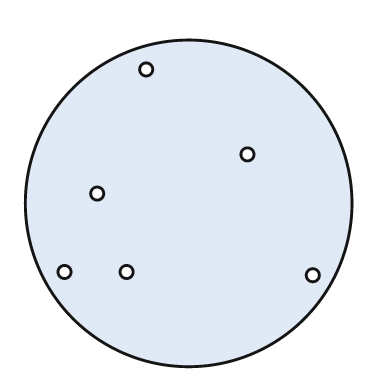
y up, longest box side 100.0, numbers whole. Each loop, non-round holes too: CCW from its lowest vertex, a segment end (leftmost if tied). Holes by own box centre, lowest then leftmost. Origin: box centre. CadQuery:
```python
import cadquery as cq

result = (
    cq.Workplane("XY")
    .moveTo(0.0, 0.0)
    .circle(50.0)
    .moveTo(38.0, -22.0)
    .circle(2.0)
    .moveTo(-38.0, -21.0)
    .circle(2.0)
    .moveTo(-19.0, -21.0)
    .circle(2.0)
    .moveTo(-28.0, 3.0)
    .circle(2.0)
    .moveTo(18.0, 15.0)
    .circle(2.0)
    .moveTo(-13.0, 41.0)
    .circle(2.0)
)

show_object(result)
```